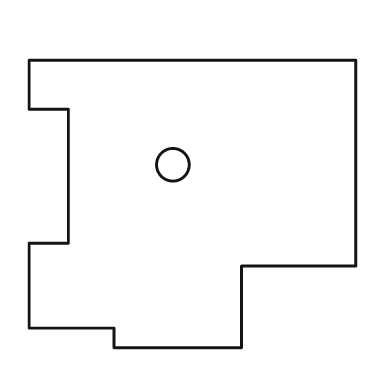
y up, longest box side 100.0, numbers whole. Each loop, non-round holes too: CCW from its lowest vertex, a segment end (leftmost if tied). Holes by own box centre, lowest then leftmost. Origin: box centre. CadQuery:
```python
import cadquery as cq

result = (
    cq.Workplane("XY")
    .moveTo(-24.0, -44.0)
    .lineTo(15.0, -44.0)
    .lineTo(15.0, -19.0)
    .lineTo(50.0, -19.0)
    .lineTo(50.0, 44.0)
    .lineTo(-50.0, 44.0)
    .lineTo(-50.0, 29.0)
    .lineTo(-38.0, 29.0)
    .lineTo(-38.0, -12.0)
    .lineTo(-50.0, -12.0)
    .lineTo(-50.0, -38.0)
    .lineTo(-24.0, -38.0)
    .close()
    .moveTo(-6.0, 12.0)
    .circle(5.0)
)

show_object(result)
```